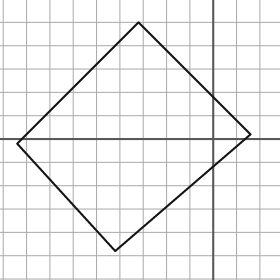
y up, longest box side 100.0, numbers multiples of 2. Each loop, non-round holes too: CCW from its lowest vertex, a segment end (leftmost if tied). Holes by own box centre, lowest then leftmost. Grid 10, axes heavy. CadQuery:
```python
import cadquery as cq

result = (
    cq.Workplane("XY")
    .moveTo(-42.0, -48.0)
    .lineTo(16.0, 2.0)
    .lineTo(-32.0, 50.0)
    .lineTo(-84.0, -2.0)
    .close()
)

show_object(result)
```